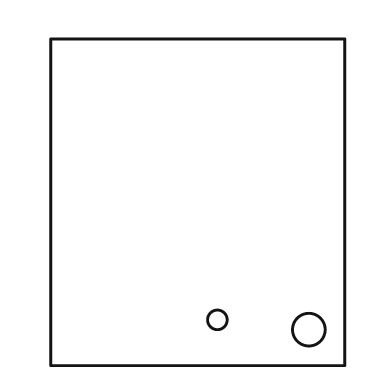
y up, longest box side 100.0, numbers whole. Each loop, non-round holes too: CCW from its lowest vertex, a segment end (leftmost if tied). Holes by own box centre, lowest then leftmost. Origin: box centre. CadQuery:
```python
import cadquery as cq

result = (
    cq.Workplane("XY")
    .moveTo(-45.0, -50.0)
    .lineTo(45.0, -50.0)
    .lineTo(45.0, 50.0)
    .lineTo(-45.0, 50.0)
    .close()
    .moveTo(34.0, -39.0)
    .circle(5.0)
    .moveTo(6.0, -36.0)
    .circle(3.0)
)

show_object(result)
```